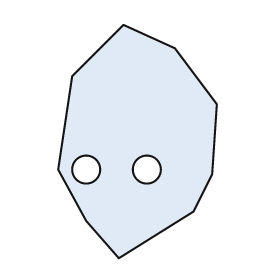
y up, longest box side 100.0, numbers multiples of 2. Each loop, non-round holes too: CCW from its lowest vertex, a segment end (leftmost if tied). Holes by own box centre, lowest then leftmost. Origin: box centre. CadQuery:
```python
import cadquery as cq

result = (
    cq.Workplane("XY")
    .moveTo(-8.0, -50.0)
    .lineTo(24.0, -30.0)
    .lineTo(32.0, -14.0)
    .lineTo(34.0, 16.0)
    .lineTo(16.0, 40.0)
    .lineTo(-6.0, 50.0)
    .lineTo(-28.0, 28.0)
    .lineTo(-34.0, -12.0)
    .lineTo(-22.0, -34.0)
    .close()
    .moveTo(-22.0, -12.0)
    .circle(6.0)
    .moveTo(4.0, -12.0)
    .circle(6.0)
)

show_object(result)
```